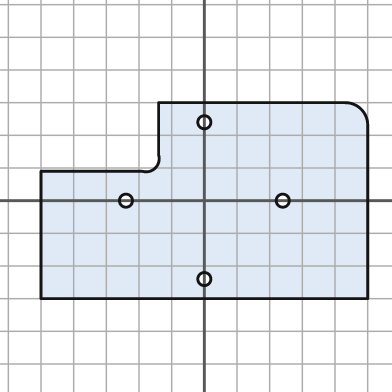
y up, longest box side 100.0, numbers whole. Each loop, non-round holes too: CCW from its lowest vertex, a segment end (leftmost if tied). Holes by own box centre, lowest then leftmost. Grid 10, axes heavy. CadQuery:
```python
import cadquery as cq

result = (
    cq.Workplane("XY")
    .moveTo(-50.0, -30.0)
    .lineTo(50.0, -30.0)
    .lineTo(50.0, 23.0)
    .threePointArc((48.0, 28.0), (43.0, 30.0))
    .lineTo(-14.0, 30.0)
    .lineTo(-14.0, 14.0)
    .threePointArc((-15.0, 10.0), (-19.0, 9.0))
    .lineTo(-50.0, 9.0)
    .close()
    .moveTo(0.0, -24.0)
    .circle(2.0)
    .moveTo(-24.0, 0.0)
    .circle(2.0)
    .moveTo(24.0, 0.0)
    .circle(2.0)
    .moveTo(0.0, 24.0)
    .circle(2.0)
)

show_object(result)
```